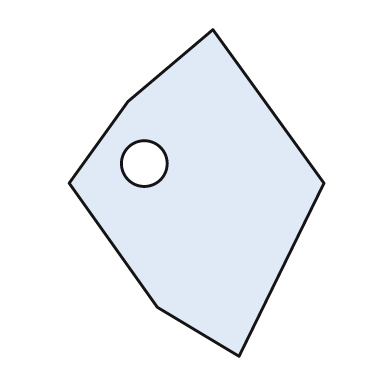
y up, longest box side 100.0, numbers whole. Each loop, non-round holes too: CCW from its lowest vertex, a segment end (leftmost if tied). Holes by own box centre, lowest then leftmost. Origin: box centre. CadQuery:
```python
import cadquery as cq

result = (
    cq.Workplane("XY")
    .moveTo(13.0, -50.0)
    .lineTo(39.0, 3.0)
    .lineTo(5.0, 50.0)
    .lineTo(-21.0, 28.0)
    .lineTo(-39.0, 3.0)
    .lineTo(-12.0, -35.0)
    .close()
    .moveTo(-16.0, 9.0)
    .circle(7.0)
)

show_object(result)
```